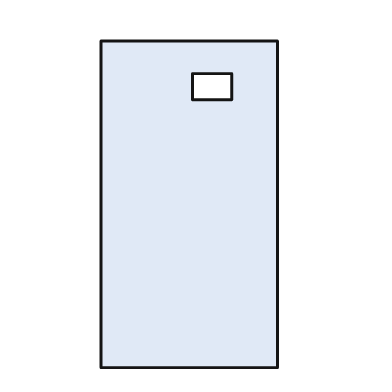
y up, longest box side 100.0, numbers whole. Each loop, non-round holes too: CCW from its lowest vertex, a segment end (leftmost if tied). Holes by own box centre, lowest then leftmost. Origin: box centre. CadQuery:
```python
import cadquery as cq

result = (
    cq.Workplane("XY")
    .moveTo(-27.0, -50.0)
    .lineTo(27.0, -50.0)
    .lineTo(27.0, 50.0)
    .lineTo(-27.0, 50.0)
    .close()
    .moveTo(1.0, 32.0)
    .lineTo(13.0, 32.0)
    .lineTo(13.0, 40.0)
    .lineTo(1.0, 40.0)
    .close()
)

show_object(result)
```